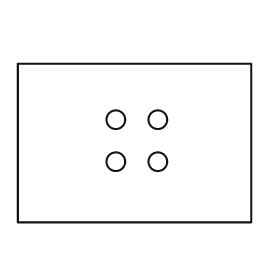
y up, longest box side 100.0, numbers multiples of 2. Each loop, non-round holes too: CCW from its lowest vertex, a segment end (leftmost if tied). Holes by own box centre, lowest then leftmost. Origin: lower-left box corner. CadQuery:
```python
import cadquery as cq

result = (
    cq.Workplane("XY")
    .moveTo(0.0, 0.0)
    .lineTo(100.0, 0.0)
    .lineTo(100.0, 68.0)
    .lineTo(0.0, 68.0)
    .close()
    .moveTo(42.0, 26.0)
    .circle(4.0)
    .moveTo(60.0, 26.0)
    .circle(4.0)
    .moveTo(42.0, 44.0)
    .circle(4.0)
    .moveTo(60.0, 44.0)
    .circle(4.0)
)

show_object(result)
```